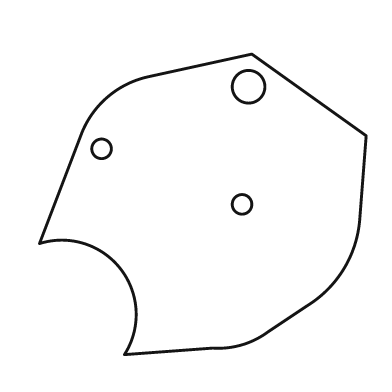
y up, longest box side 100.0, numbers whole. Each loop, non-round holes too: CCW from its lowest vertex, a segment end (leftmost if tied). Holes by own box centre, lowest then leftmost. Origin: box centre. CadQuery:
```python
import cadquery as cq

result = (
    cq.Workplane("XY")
    .moveTo(-24.0, -46.0)
    .lineTo(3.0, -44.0)
    .threePointArc((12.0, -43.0), (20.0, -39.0))
    .lineTo(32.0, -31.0)
    .threePointArc((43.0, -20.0), (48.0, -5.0))
    .lineTo(50.0, 21.0)
    .lineTo(15.0, 46.0)
    .lineTo(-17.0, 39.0)
    .threePointArc((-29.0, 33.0), (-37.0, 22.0))
    .lineTo(-50.0, -12.0)
    .threePointArc((-25.0, -20.0), (-24.0, -46.0))
    .close()
    .moveTo(12.0, 0.0)
    .circle(3.0)
    .moveTo(-31.0, 17.0)
    .circle(3.0)
    .moveTo(14.0, 36.0)
    .circle(5.0)
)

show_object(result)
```